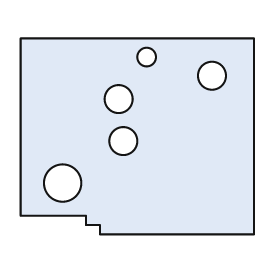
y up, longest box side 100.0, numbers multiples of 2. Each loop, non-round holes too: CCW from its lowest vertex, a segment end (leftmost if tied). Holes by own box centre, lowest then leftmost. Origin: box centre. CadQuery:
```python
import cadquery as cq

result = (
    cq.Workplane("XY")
    .moveTo(-16.0, -42.0)
    .lineTo(50.0, -42.0)
    .lineTo(50.0, 42.0)
    .lineTo(-50.0, 42.0)
    .lineTo(-50.0, -34.0)
    .lineTo(-22.0, -34.0)
    .lineTo(-22.0, -38.0)
    .lineTo(-16.0, -38.0)
    .close()
    .moveTo(-32.0, -20.0)
    .circle(8.0)
    .moveTo(-6.0, -2.0)
    .circle(6.0)
    .moveTo(-8.0, 16.0)
    .circle(6.0)
    .moveTo(32.0, 26.0)
    .circle(6.0)
    .moveTo(4.0, 34.0)
    .circle(4.0)
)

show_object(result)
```